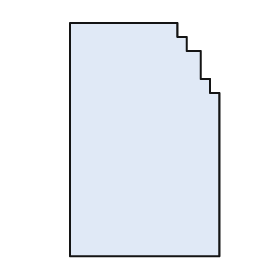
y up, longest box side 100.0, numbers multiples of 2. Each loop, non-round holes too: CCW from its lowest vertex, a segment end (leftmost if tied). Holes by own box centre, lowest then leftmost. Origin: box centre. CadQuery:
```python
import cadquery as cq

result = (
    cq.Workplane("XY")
    .moveTo(-32.0, -50.0)
    .lineTo(32.0, -50.0)
    .lineTo(32.0, 20.0)
    .lineTo(28.0, 20.0)
    .lineTo(28.0, 26.0)
    .lineTo(24.0, 26.0)
    .lineTo(24.0, 38.0)
    .lineTo(18.0, 38.0)
    .lineTo(18.0, 44.0)
    .lineTo(14.0, 44.0)
    .lineTo(14.0, 50.0)
    .lineTo(-32.0, 50.0)
    .close()
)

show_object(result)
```